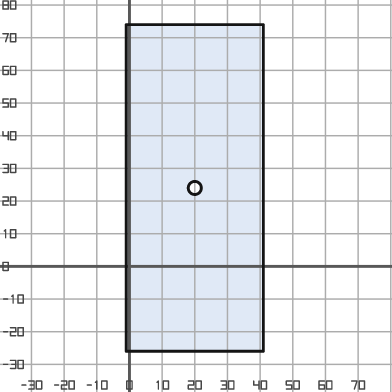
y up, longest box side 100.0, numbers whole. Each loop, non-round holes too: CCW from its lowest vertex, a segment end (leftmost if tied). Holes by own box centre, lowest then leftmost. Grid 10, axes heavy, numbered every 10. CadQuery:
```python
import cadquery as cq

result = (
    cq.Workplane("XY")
    .moveTo(-1.0, -26.0)
    .lineTo(41.0, -26.0)
    .lineTo(41.0, 74.0)
    .lineTo(-1.0, 74.0)
    .close()
    .moveTo(20.0, 24.0)
    .circle(2.0)
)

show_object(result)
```